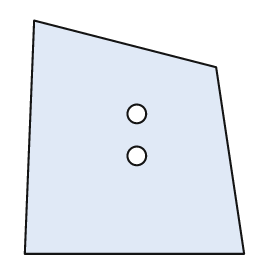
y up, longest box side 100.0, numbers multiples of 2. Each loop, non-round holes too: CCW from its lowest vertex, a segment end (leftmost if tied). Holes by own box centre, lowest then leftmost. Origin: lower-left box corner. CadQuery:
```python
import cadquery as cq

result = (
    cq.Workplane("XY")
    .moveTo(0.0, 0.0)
    .lineTo(94.0, 0.0)
    .lineTo(82.0, 80.0)
    .lineTo(4.0, 100.0)
    .close()
    .moveTo(48.0, 42.0)
    .circle(4.0)
    .moveTo(48.0, 60.0)
    .circle(4.0)
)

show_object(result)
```